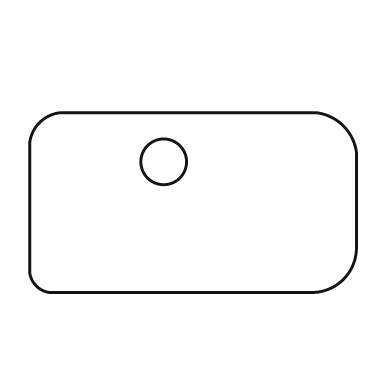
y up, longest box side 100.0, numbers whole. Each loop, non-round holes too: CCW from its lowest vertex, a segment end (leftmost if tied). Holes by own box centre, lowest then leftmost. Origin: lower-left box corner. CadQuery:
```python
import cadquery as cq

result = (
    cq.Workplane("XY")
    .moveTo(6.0, 0.0)
    .lineTo(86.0, 0.0)
    .threePointArc((96.0, 4.0), (100.0, 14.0))
    .lineTo(100.0, 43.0)
    .threePointArc((96.0, 51.0), (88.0, 55.0))
    .lineTo(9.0, 55.0)
    .threePointArc((3.0, 52.0), (0.0, 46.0))
    .lineTo(0.0, 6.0)
    .threePointArc((2.0, 2.0), (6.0, 0.0))
    .close()
    .moveTo(41.0, 40.0)
    .circle(7.0)
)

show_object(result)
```